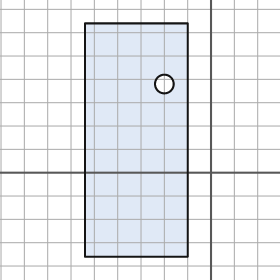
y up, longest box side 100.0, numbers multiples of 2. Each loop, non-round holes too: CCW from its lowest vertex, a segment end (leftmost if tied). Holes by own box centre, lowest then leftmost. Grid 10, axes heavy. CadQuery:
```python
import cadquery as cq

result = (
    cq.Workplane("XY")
    .moveTo(-54.0, -36.0)
    .lineTo(-10.0, -36.0)
    .lineTo(-10.0, 64.0)
    .lineTo(-54.0, 64.0)
    .close()
    .moveTo(-20.0, 38.0)
    .circle(4.0)
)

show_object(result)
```